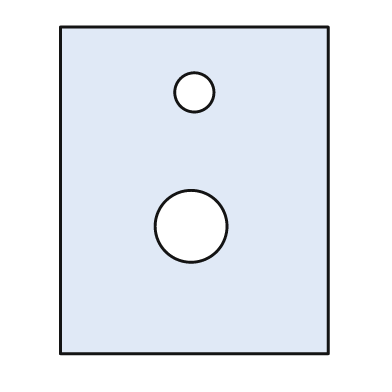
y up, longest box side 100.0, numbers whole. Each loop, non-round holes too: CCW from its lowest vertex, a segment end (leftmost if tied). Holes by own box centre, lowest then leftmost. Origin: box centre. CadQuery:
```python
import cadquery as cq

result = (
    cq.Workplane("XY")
    .moveTo(-41.0, -50.0)
    .lineTo(41.0, -50.0)
    .lineTo(41.0, 50.0)
    .lineTo(-41.0, 50.0)
    .close()
    .moveTo(-1.0, -11.0)
    .circle(11.0)
    .moveTo(0.0, 30.0)
    .circle(6.0)
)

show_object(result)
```